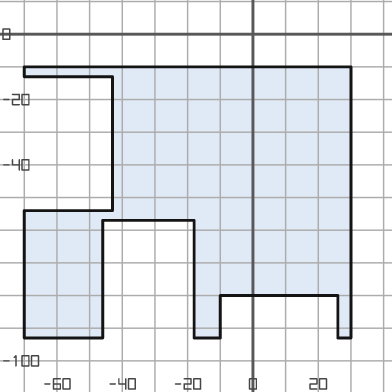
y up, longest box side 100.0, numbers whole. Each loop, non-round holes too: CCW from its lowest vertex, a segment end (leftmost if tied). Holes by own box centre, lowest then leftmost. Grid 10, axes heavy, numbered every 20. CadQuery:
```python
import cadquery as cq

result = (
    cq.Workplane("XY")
    .moveTo(-70.0, -93.0)
    .lineTo(-46.0, -93.0)
    .lineTo(-46.0, -57.0)
    .lineTo(-18.0, -57.0)
    .lineTo(-18.0, -93.0)
    .lineTo(-10.0, -93.0)
    .lineTo(-10.0, -80.0)
    .lineTo(26.0, -80.0)
    .lineTo(26.0, -93.0)
    .lineTo(30.0, -93.0)
    .lineTo(30.0, -10.0)
    .lineTo(-70.0, -10.0)
    .lineTo(-70.0, -13.0)
    .lineTo(-43.0, -13.0)
    .lineTo(-43.0, -54.0)
    .lineTo(-70.0, -54.0)
    .close()
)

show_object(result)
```